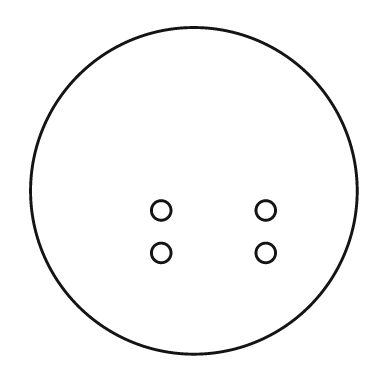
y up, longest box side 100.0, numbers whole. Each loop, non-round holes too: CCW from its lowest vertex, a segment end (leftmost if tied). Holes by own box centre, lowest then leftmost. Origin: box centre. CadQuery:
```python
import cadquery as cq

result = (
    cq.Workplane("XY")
    .moveTo(0.0, 0.0)
    .circle(50.0)
    .moveTo(-10.0, -19.0)
    .circle(3.0)
    .moveTo(22.0, -19.0)
    .circle(3.0)
    .moveTo(-10.0, -6.0)
    .circle(3.0)
    .moveTo(22.0, -6.0)
    .circle(3.0)
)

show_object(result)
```